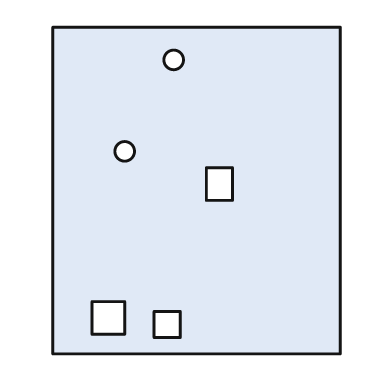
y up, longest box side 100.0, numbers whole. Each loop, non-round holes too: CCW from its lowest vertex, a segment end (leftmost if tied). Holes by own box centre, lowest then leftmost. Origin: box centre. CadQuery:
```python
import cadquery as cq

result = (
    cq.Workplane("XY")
    .moveTo(-44.0, -50.0)
    .lineTo(44.0, -50.0)
    .lineTo(44.0, 50.0)
    .lineTo(-44.0, 50.0)
    .close()
    .moveTo(-13.0, -45.0)
    .lineTo(-5.0, -45.0)
    .lineTo(-5.0, -37.0)
    .lineTo(-13.0, -37.0)
    .close()
    .moveTo(-32.0, -44.0)
    .lineTo(-22.0, -44.0)
    .lineTo(-22.0, -34.0)
    .lineTo(-32.0, -34.0)
    .close()
    .moveTo(3.0, -3.0)
    .lineTo(11.0, -3.0)
    .lineTo(11.0, 7.0)
    .lineTo(3.0, 7.0)
    .close()
    .moveTo(-22.0, 12.0)
    .circle(3.0)
    .moveTo(-7.0, 40.0)
    .circle(3.0)
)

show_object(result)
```